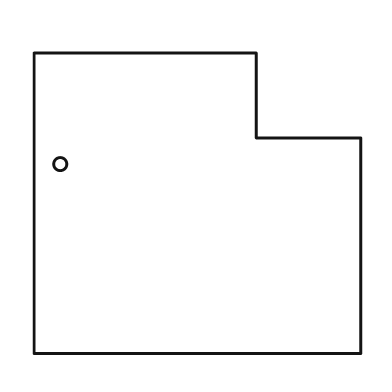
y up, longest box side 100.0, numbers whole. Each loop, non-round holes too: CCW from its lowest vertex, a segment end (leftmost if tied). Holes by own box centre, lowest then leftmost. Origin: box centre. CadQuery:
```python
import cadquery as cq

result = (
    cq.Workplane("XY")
    .moveTo(-50.0, -46.0)
    .lineTo(50.0, -46.0)
    .lineTo(50.0, 20.0)
    .lineTo(18.0, 20.0)
    .lineTo(18.0, 46.0)
    .lineTo(-50.0, 46.0)
    .close()
    .moveTo(-42.0, 12.0)
    .circle(2.0)
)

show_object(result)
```